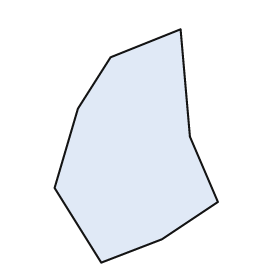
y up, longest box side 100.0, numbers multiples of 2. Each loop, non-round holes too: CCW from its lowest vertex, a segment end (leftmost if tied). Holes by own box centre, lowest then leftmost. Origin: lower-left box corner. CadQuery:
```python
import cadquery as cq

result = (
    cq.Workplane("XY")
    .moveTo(20.0, 0.0)
    .lineTo(46.0, 10.0)
    .lineTo(70.0, 26.0)
    .lineTo(58.0, 54.0)
    .lineTo(54.0, 100.0)
    .lineTo(24.0, 88.0)
    .lineTo(10.0, 66.0)
    .lineTo(0.0, 32.0)
    .close()
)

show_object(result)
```